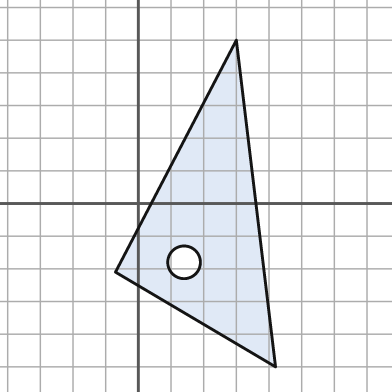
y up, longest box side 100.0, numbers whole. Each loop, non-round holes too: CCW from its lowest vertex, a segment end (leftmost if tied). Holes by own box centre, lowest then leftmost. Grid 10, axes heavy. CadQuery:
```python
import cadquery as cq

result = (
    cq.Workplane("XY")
    .moveTo(42.0, -50.0)
    .lineTo(30.0, 50.0)
    .lineTo(-7.0, -21.0)
    .close()
    .moveTo(14.0, -18.0)
    .circle(5.0)
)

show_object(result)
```